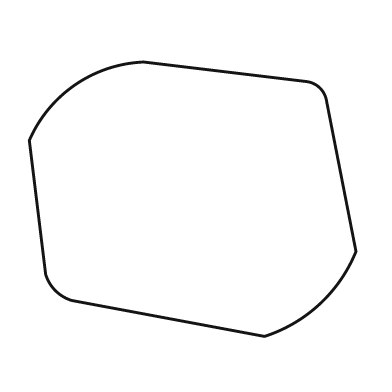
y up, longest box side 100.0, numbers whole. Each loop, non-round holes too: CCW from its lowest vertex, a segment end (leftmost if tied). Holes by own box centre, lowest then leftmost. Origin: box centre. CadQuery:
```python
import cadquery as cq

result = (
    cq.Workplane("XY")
    .moveTo(22.0, -42.0)
    .threePointArc((39.0, -32.0), (50.0, -16.0))
    .lineTo(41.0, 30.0)
    .threePointArc((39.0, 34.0), (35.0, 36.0))
    .lineTo(-15.0, 42.0)
    .threePointArc((-36.0, 35.0), (-50.0, 18.0))
    .lineTo(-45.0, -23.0)
    .threePointArc((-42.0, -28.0), (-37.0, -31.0))
    .close()
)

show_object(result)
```